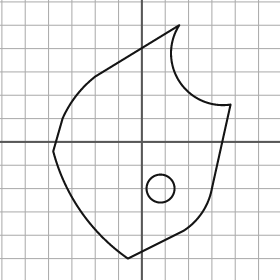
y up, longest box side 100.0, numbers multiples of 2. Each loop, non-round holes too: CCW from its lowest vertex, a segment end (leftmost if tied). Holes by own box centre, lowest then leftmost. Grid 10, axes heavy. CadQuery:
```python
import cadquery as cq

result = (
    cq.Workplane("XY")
    .moveTo(-6.0, -50.0)
    .lineTo(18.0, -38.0)
    .threePointArc((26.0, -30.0), (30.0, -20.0))
    .lineTo(38.0, 16.0)
    .threePointArc((16.0, 26.0), (16.0, 50.0))
    .lineTo(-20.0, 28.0)
    .threePointArc((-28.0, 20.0), (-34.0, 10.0))
    .lineTo(-38.0, -4.0)
    .threePointArc((-26.0, -30.0), (-6.0, -50.0))
    .close()
    .moveTo(8.0, -20.0)
    .circle(6.0)
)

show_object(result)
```